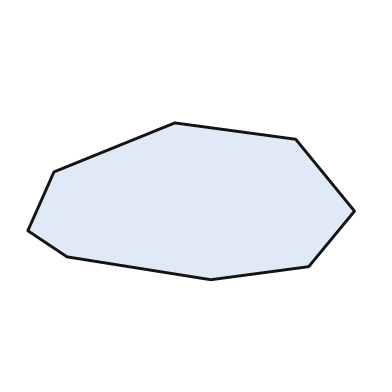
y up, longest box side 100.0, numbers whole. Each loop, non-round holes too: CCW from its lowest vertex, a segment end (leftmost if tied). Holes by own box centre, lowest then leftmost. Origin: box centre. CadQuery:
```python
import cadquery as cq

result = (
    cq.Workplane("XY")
    .moveTo(6.0, -24.0)
    .lineTo(36.0, -20.0)
    .lineTo(50.0, -3.0)
    .lineTo(32.0, 19.0)
    .lineTo(-5.0, 24.0)
    .lineTo(-42.0, 9.0)
    .lineTo(-50.0, -9.0)
    .lineTo(-38.0, -17.0)
    .close()
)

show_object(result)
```